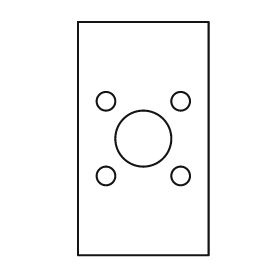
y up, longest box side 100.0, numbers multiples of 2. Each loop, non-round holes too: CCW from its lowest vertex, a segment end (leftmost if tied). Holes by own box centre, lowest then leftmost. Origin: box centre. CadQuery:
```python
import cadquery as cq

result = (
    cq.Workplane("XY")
    .moveTo(-28.0, -50.0)
    .lineTo(28.0, -50.0)
    .lineTo(28.0, 50.0)
    .lineTo(-28.0, 50.0)
    .close()
    .moveTo(-16.0, -16.0)
    .circle(4.0)
    .moveTo(16.0, -16.0)
    .circle(4.0)
    .moveTo(0.0, 0.0)
    .circle(12.0)
    .moveTo(-16.0, 16.0)
    .circle(4.0)
    .moveTo(16.0, 16.0)
    .circle(4.0)
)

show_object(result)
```